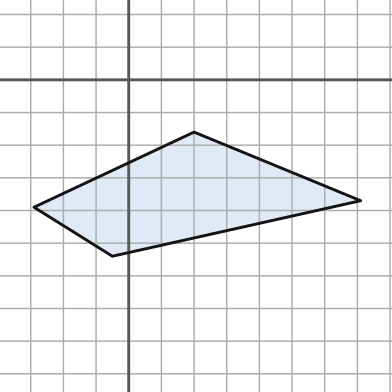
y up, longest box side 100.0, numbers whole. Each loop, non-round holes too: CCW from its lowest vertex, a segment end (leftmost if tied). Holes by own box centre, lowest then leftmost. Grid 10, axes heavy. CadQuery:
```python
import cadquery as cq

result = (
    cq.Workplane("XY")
    .moveTo(-5.0, -54.0)
    .lineTo(71.0, -37.0)
    .lineTo(20.0, -16.0)
    .lineTo(-29.0, -39.0)
    .close()
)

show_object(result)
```